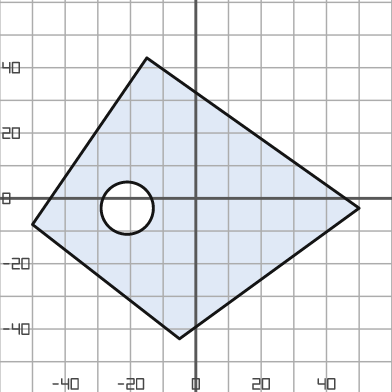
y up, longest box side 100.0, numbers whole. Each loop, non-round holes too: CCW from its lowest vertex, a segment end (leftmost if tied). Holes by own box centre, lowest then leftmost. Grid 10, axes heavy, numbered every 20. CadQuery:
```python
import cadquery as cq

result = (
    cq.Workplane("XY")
    .moveTo(-5.0, -43.0)
    .lineTo(50.0, -3.0)
    .lineTo(-15.0, 43.0)
    .lineTo(-50.0, -8.0)
    .close()
    .moveTo(-21.0, -3.0)
    .circle(8.0)
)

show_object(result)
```